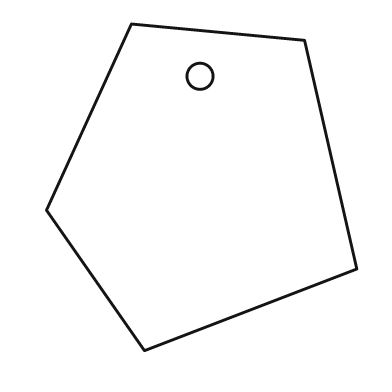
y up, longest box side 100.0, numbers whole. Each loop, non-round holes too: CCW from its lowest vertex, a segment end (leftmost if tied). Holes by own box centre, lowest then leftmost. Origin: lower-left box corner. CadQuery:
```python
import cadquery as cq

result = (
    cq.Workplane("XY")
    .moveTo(30.0, 0.0)
    .lineTo(95.0, 25.0)
    .lineTo(79.0, 95.0)
    .lineTo(26.0, 100.0)
    .lineTo(0.0, 43.0)
    .close()
    .moveTo(47.0, 84.0)
    .circle(4.0)
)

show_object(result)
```